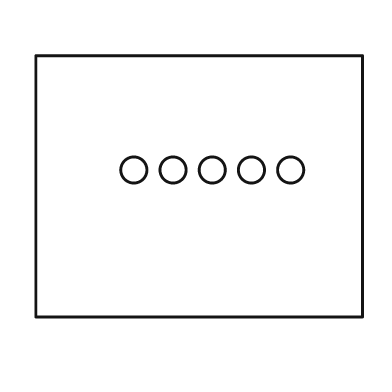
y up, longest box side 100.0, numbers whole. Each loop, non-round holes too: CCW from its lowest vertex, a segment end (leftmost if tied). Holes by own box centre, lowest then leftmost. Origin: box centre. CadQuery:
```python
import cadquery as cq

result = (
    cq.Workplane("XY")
    .moveTo(-50.0, -40.0)
    .lineTo(50.0, -40.0)
    .lineTo(50.0, 40.0)
    .lineTo(-50.0, 40.0)
    .close()
    .moveTo(-20.0, 5.0)
    .circle(4.0)
    .moveTo(-8.0, 5.0)
    .circle(4.0)
    .moveTo(4.0, 5.0)
    .circle(4.0)
    .moveTo(16.0, 5.0)
    .circle(4.0)
    .moveTo(28.0, 5.0)
    .circle(4.0)
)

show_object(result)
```